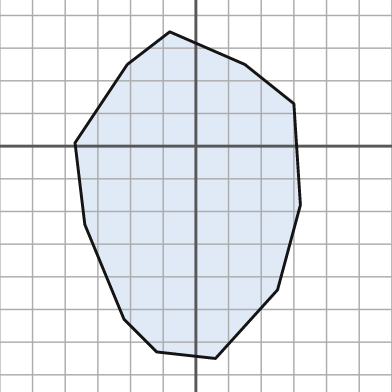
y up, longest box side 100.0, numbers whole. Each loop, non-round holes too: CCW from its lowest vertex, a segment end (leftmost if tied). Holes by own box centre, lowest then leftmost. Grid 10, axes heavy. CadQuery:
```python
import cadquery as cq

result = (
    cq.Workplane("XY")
    .moveTo(6.0, -65.0)
    .lineTo(25.0, -44.0)
    .lineTo(32.0, -18.0)
    .lineTo(30.0, 13.0)
    .lineTo(15.0, 25.0)
    .lineTo(-8.0, 35.0)
    .lineTo(-21.0, 25.0)
    .lineTo(-37.0, 1.0)
    .lineTo(-34.0, -24.0)
    .lineTo(-22.0, -53.0)
    .lineTo(-12.0, -63.0)
    .close()
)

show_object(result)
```